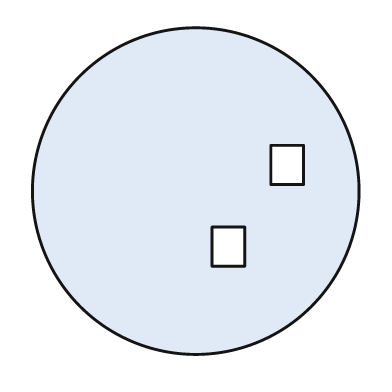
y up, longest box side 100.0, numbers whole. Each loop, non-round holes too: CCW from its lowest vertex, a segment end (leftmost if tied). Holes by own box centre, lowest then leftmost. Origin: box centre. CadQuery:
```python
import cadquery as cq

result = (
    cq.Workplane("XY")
    .moveTo(0.0, 0.0)
    .circle(50.0)
    .moveTo(5.0, -23.0)
    .lineTo(15.0, -23.0)
    .lineTo(15.0, -11.0)
    .lineTo(5.0, -11.0)
    .close()
    .moveTo(23.0, 2.0)
    .lineTo(33.0, 2.0)
    .lineTo(33.0, 14.0)
    .lineTo(23.0, 14.0)
    .close()
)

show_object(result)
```